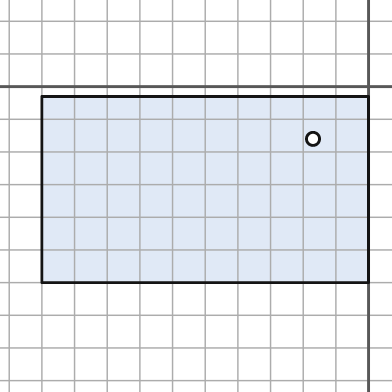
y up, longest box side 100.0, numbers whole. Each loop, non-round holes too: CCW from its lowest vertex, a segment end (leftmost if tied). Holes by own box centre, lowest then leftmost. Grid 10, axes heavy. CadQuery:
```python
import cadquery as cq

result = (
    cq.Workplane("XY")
    .moveTo(-100.0, -60.0)
    .lineTo(0.0, -60.0)
    .lineTo(0.0, -3.0)
    .lineTo(-100.0, -3.0)
    .close()
    .moveTo(-17.0, -16.0)
    .circle(2.0)
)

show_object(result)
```